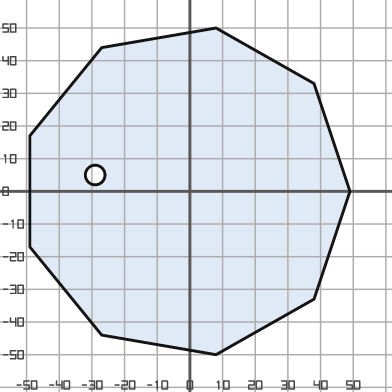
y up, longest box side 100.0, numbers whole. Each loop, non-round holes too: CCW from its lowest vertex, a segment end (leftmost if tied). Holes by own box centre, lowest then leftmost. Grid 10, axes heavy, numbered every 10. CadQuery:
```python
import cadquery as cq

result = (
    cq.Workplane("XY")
    .moveTo(8.0, -50.0)
    .lineTo(38.0, -33.0)
    .lineTo(49.0, 0.0)
    .lineTo(38.0, 33.0)
    .lineTo(8.0, 50.0)
    .lineTo(-27.0, 44.0)
    .lineTo(-49.0, 17.0)
    .lineTo(-49.0, -17.0)
    .lineTo(-27.0, -44.0)
    .close()
    .moveTo(-29.0, 5.0)
    .circle(3.0)
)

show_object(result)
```